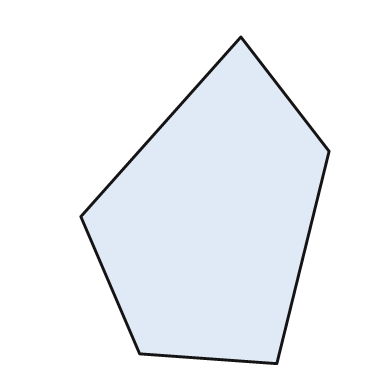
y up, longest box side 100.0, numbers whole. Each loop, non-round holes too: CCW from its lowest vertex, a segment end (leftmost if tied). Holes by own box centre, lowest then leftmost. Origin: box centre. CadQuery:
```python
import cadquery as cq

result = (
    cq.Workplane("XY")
    .moveTo(22.0, -50.0)
    .lineTo(38.0, 15.0)
    .lineTo(11.0, 50.0)
    .lineTo(-38.0, -5.0)
    .lineTo(-20.0, -47.0)
    .close()
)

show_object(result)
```